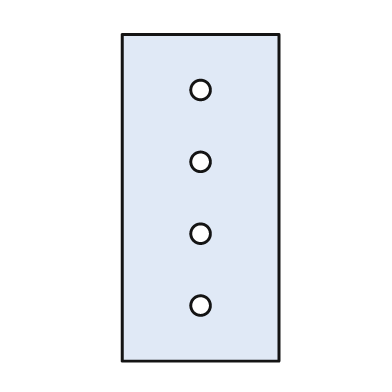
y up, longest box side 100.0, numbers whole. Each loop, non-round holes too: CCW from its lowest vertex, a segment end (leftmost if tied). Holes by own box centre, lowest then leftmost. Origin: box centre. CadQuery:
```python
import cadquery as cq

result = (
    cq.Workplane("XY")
    .moveTo(-24.0, -50.0)
    .lineTo(24.0, -50.0)
    .lineTo(24.0, 50.0)
    .lineTo(-24.0, 50.0)
    .close()
    .moveTo(0.0, -33.0)
    .circle(3.0)
    .moveTo(0.0, -11.0)
    .circle(3.0)
    .moveTo(0.0, 11.0)
    .circle(3.0)
    .moveTo(0.0, 33.0)
    .circle(3.0)
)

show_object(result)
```